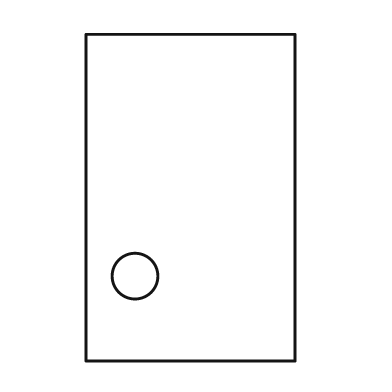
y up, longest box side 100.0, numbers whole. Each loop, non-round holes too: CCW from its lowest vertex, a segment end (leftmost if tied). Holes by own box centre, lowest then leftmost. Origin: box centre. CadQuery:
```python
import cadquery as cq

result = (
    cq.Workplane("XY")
    .moveTo(-32.0, -50.0)
    .lineTo(32.0, -50.0)
    .lineTo(32.0, 50.0)
    .lineTo(-32.0, 50.0)
    .close()
    .moveTo(-17.0, -24.0)
    .circle(7.0)
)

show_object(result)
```